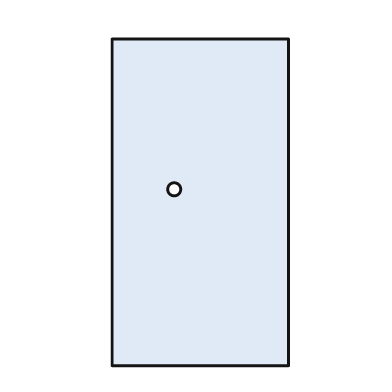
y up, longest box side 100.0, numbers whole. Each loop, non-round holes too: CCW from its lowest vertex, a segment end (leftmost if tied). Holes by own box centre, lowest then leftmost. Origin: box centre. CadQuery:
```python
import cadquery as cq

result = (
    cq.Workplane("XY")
    .moveTo(-27.0, -50.0)
    .lineTo(27.0, -50.0)
    .lineTo(27.0, 50.0)
    .lineTo(-27.0, 50.0)
    .close()
    .moveTo(-8.0, 4.0)
    .circle(2.0)
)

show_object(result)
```